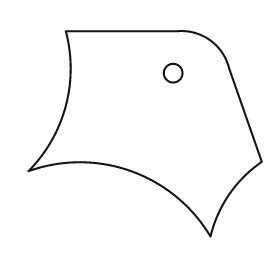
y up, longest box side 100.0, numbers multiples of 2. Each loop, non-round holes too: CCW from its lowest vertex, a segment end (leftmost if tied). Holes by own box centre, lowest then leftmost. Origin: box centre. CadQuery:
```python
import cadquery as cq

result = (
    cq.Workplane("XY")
    .moveTo(28.0, -44.0)
    .threePointArc((36.0, -26.0), (50.0, -12.0))
    .lineTo(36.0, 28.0)
    .threePointArc((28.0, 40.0), (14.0, 44.0))
    .lineTo(-34.0, 44.0)
    .threePointArc((-34.0, 12.0), (-50.0, -16.0))
    .threePointArc((-6.0, -16.0), (28.0, -44.0))
    .close()
    .moveTo(12.0, 26.0)
    .circle(4.0)
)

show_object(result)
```